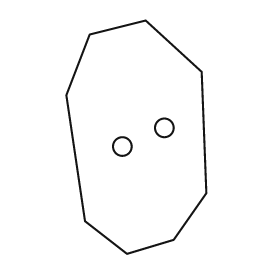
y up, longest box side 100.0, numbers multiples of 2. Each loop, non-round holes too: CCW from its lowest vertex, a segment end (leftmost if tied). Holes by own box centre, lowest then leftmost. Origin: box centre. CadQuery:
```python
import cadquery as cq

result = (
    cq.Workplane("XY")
    .moveTo(-4.0, -50.0)
    .lineTo(16.0, -44.0)
    .lineTo(30.0, -24.0)
    .lineTo(28.0, 28.0)
    .lineTo(4.0, 50.0)
    .lineTo(-20.0, 44.0)
    .lineTo(-30.0, 18.0)
    .lineTo(-22.0, -36.0)
    .close()
    .moveTo(-6.0, -4.0)
    .circle(4.0)
    .moveTo(12.0, 4.0)
    .circle(4.0)
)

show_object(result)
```